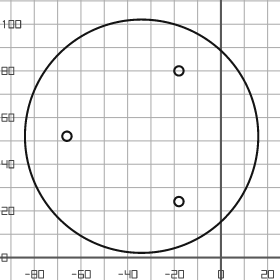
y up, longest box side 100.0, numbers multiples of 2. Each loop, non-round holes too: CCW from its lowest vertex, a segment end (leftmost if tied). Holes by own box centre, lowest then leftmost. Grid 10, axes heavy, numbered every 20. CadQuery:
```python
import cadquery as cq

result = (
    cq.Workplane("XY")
    .moveTo(-34.0, 52.0)
    .circle(50.0)
    .moveTo(-18.0, 24.0)
    .circle(2.0)
    .moveTo(-66.0, 52.0)
    .circle(2.0)
    .moveTo(-18.0, 80.0)
    .circle(2.0)
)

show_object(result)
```